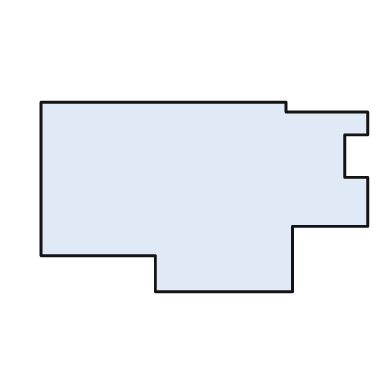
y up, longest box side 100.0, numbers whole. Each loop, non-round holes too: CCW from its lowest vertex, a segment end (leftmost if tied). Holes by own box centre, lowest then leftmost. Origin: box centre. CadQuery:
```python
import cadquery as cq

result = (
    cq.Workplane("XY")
    .moveTo(-15.0, -29.0)
    .lineTo(27.0, -29.0)
    .lineTo(27.0, -9.0)
    .lineTo(50.0, -9.0)
    .lineTo(50.0, 6.0)
    .lineTo(43.0, 6.0)
    .lineTo(43.0, 19.0)
    .lineTo(50.0, 19.0)
    .lineTo(50.0, 26.0)
    .lineTo(25.0, 26.0)
    .lineTo(25.0, 29.0)
    .lineTo(-50.0, 29.0)
    .lineTo(-50.0, -18.0)
    .lineTo(-15.0, -18.0)
    .close()
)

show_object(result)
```